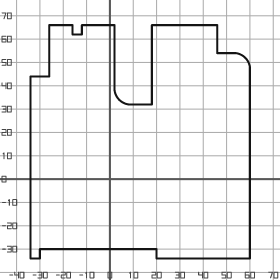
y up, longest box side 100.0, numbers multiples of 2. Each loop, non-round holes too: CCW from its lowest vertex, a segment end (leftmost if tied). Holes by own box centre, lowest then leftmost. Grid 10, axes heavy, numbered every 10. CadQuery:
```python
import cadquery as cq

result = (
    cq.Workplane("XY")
    .moveTo(-34.0, -34.0)
    .lineTo(-30.0, -34.0)
    .lineTo(-30.0, -30.0)
    .lineTo(20.0, -30.0)
    .lineTo(20.0, -34.0)
    .lineTo(60.0, -34.0)
    .lineTo(60.0, 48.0)
    .threePointArc((58.0, 52.0), (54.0, 54.0))
    .lineTo(46.0, 54.0)
    .lineTo(46.0, 66.0)
    .lineTo(18.0, 66.0)
    .lineTo(18.0, 32.0)
    .lineTo(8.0, 32.0)
    .threePointArc((4.0, 34.0), (2.0, 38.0))
    .lineTo(2.0, 66.0)
    .lineTo(-12.0, 66.0)
    .lineTo(-12.0, 62.0)
    .lineTo(-16.0, 62.0)
    .lineTo(-16.0, 66.0)
    .lineTo(-26.0, 66.0)
    .lineTo(-26.0, 44.0)
    .lineTo(-34.0, 44.0)
    .close()
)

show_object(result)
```